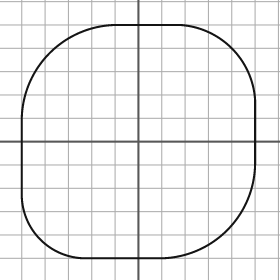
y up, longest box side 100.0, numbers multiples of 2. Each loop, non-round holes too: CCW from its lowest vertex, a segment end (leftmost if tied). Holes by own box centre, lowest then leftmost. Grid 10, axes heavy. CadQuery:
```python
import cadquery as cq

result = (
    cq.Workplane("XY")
    .moveTo(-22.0, -50.0)
    .lineTo(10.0, -50.0)
    .threePointArc((38.0, -38.0), (50.0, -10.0))
    .lineTo(50.0, 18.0)
    .threePointArc((40.0, 40.0), (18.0, 50.0))
    .lineTo(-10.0, 50.0)
    .threePointArc((-38.0, 38.0), (-50.0, 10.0))
    .lineTo(-50.0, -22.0)
    .threePointArc((-42.0, -42.0), (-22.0, -50.0))
    .close()
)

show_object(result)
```